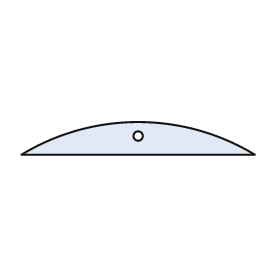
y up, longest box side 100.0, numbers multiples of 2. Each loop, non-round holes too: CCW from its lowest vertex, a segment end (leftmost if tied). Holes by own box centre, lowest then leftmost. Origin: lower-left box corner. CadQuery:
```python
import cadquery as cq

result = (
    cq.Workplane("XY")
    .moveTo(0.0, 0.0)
    .lineTo(100.0, 0.0)
    .threePointArc((50.0, 14.0), (0.0, 0.0))
    .close()
    .moveTo(50.0, 8.0)
    .circle(2.0)
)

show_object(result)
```